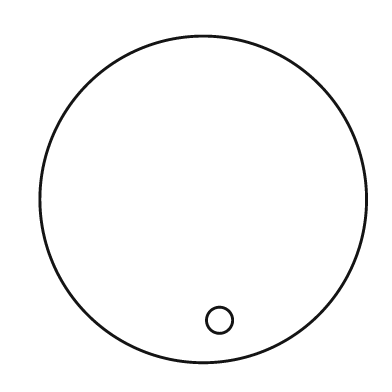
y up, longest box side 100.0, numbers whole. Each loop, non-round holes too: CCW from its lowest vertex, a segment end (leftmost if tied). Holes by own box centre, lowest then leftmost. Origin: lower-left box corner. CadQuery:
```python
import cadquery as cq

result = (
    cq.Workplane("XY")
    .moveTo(50.0, 50.0)
    .circle(50.0)
    .moveTo(55.0, 13.0)
    .circle(4.0)
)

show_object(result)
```